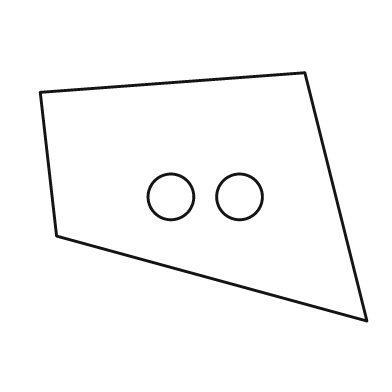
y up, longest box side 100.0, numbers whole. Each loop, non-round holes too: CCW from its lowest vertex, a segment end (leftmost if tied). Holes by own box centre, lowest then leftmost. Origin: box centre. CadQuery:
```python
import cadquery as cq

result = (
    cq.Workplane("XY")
    .moveTo(50.0, -38.0)
    .lineTo(31.0, 38.0)
    .lineTo(-50.0, 32.0)
    .lineTo(-45.0, -12.0)
    .close()
    .moveTo(-10.0, 0.0)
    .circle(7.0)
    .moveTo(11.0, 0.0)
    .circle(7.0)
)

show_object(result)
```